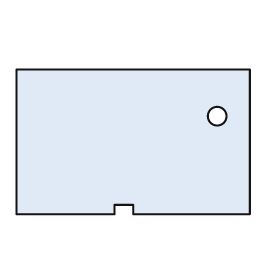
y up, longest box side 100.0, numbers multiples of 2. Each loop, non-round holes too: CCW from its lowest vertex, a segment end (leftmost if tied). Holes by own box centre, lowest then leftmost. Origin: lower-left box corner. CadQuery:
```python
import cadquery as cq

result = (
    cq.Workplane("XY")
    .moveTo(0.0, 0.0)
    .lineTo(42.0, 0.0)
    .lineTo(42.0, 4.0)
    .lineTo(50.0, 4.0)
    .lineTo(50.0, 0.0)
    .lineTo(100.0, 0.0)
    .lineTo(100.0, 62.0)
    .lineTo(0.0, 62.0)
    .close()
    .moveTo(86.0, 42.0)
    .circle(4.0)
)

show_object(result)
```